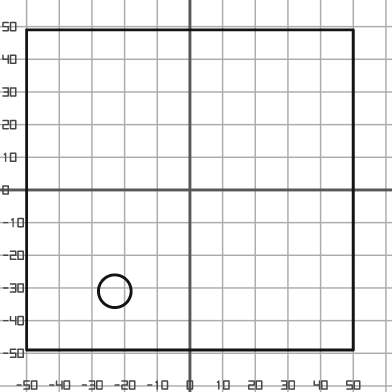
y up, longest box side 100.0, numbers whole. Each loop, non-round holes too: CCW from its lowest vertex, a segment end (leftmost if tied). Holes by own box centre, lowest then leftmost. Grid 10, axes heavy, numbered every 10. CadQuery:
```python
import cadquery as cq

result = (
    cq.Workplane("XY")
    .moveTo(-50.0, -49.0)
    .lineTo(50.0, -49.0)
    .lineTo(50.0, 49.0)
    .lineTo(-50.0, 49.0)
    .close()
    .moveTo(-23.0, -31.0)
    .circle(5.0)
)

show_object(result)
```